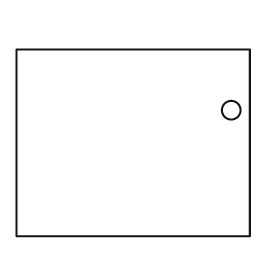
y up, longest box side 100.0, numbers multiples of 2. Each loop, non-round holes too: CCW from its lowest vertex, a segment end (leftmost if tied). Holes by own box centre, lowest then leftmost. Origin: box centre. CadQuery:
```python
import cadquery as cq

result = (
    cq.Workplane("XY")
    .moveTo(-50.0, -40.0)
    .lineTo(50.0, -40.0)
    .lineTo(50.0, 40.0)
    .lineTo(-50.0, 40.0)
    .close()
    .moveTo(42.0, 14.0)
    .circle(4.0)
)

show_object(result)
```